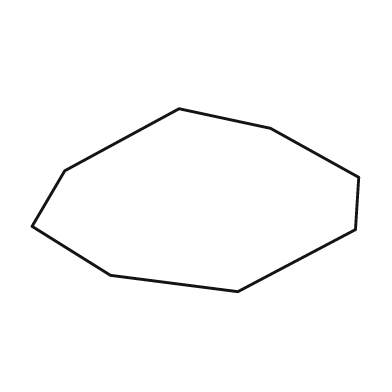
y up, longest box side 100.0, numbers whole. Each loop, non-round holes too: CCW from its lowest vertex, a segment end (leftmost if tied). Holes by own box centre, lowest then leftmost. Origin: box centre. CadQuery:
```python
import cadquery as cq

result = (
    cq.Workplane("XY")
    .moveTo(13.0, -28.0)
    .lineTo(49.0, -9.0)
    .lineTo(50.0, 7.0)
    .lineTo(23.0, 22.0)
    .lineTo(-5.0, 28.0)
    .lineTo(-40.0, 9.0)
    .lineTo(-50.0, -8.0)
    .lineTo(-26.0, -23.0)
    .close()
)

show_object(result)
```